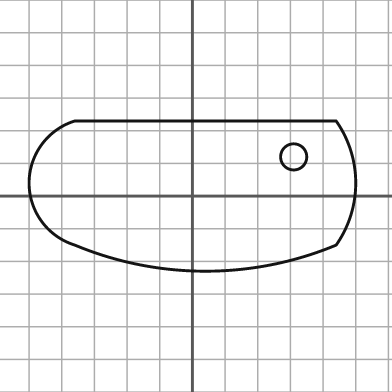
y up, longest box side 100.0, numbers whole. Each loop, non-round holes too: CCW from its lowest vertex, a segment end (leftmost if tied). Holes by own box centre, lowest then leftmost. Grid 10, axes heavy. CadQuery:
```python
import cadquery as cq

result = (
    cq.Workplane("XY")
    .moveTo(-36.0, -15.0)
    .threePointArc((4.0, -23.0), (44.0, -15.0))
    .threePointArc((50.0, 4.0), (44.0, 23.0))
    .lineTo(-36.0, 23.0)
    .threePointArc((-50.0, 4.0), (-36.0, -15.0))
    .close()
    .moveTo(31.0, 12.0)
    .circle(4.0)
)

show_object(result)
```